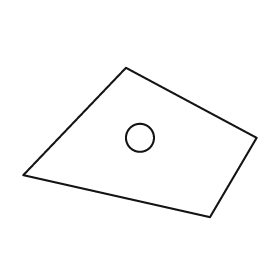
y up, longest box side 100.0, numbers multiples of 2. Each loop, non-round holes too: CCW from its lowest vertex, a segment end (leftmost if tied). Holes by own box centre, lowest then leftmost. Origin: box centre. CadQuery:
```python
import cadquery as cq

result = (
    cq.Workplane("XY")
    .moveTo(30.0, -32.0)
    .lineTo(50.0, 2.0)
    .lineTo(-6.0, 32.0)
    .lineTo(-50.0, -14.0)
    .close()
    .moveTo(0.0, 2.0)
    .circle(6.0)
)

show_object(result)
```